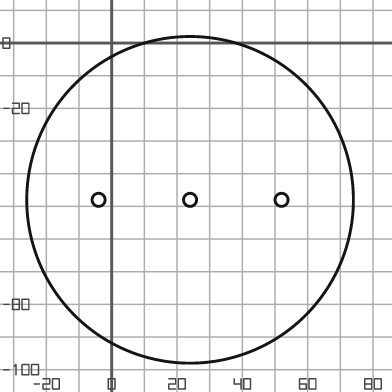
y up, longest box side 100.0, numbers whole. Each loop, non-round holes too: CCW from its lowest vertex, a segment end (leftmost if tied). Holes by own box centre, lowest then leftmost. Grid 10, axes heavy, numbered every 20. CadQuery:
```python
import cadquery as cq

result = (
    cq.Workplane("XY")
    .moveTo(24.0, -48.0)
    .circle(50.0)
    .moveTo(-4.0, -48.0)
    .circle(2.0)
    .moveTo(24.0, -48.0)
    .circle(2.0)
    .moveTo(52.0, -48.0)
    .circle(2.0)
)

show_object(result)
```